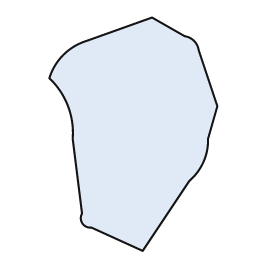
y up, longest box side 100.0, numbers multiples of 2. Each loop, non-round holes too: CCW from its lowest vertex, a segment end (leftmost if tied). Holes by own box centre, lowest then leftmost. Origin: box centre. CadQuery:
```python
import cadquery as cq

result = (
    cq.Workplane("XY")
    .moveTo(4.0, -50.0)
    .lineTo(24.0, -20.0)
    .threePointArc((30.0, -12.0), (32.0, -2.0))
    .lineTo(36.0, 12.0)
    .lineTo(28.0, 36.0)
    .threePointArc((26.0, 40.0), (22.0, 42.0))
    .lineTo(8.0, 50.0)
    .lineTo(-20.0, 40.0)
    .threePointArc((-30.0, 34.0), (-36.0, 24.0))
    .threePointArc((-28.0, 12.0), (-26.0, -2.0))
    .lineTo(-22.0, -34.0)
    .threePointArc((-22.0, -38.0), (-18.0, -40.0))
    .close()
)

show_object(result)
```